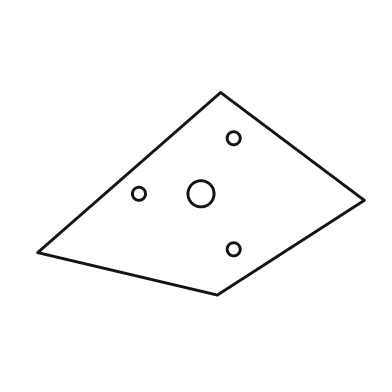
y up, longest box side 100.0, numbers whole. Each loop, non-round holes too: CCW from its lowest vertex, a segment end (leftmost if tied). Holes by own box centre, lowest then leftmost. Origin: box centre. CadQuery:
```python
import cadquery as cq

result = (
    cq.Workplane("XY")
    .moveTo(5.0, -31.0)
    .lineTo(50.0, -2.0)
    .lineTo(6.0, 31.0)
    .lineTo(-50.0, -18.0)
    .close()
    .moveTo(10.0, -17.0)
    .circle(2.0)
    .moveTo(-19.0, 0.0)
    .circle(2.0)
    .moveTo(0.0, 0.0)
    .circle(4.0)
    .moveTo(10.0, 17.0)
    .circle(2.0)
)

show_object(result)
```